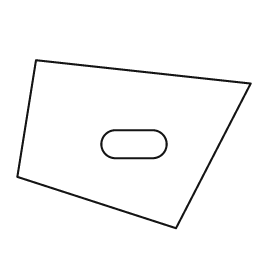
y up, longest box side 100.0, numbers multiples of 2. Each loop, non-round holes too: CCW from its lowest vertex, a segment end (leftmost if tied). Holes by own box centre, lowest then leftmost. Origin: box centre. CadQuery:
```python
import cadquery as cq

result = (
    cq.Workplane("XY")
    .moveTo(18.0, -36.0)
    .lineTo(50.0, 26.0)
    .lineTo(-42.0, 36.0)
    .lineTo(-50.0, -14.0)
    .close()
    .moveTo(-8.0, -6.0)
    .lineTo(8.0, -6.0)
    .threePointArc((14.0, 0.0), (8.0, 6.0))
    .lineTo(-8.0, 6.0)
    .threePointArc((-14.0, 0.0), (-8.0, -6.0))
    .close()
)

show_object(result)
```